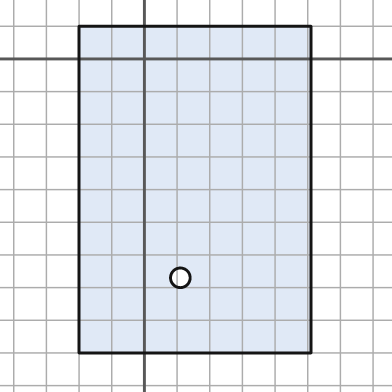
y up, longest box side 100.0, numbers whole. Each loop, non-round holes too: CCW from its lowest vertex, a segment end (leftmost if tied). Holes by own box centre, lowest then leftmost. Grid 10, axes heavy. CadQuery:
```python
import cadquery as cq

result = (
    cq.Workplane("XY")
    .moveTo(-20.0, -90.0)
    .lineTo(51.0, -90.0)
    .lineTo(51.0, 10.0)
    .lineTo(-20.0, 10.0)
    .close()
    .moveTo(11.0, -67.0)
    .circle(3.0)
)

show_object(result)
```